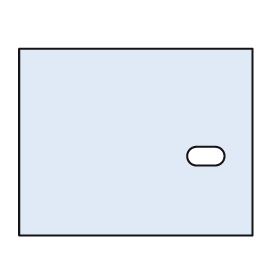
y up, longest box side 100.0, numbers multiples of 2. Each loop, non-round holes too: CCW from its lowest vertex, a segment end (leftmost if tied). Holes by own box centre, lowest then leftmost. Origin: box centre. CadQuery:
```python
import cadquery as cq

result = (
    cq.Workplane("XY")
    .moveTo(-50.0, -40.0)
    .lineTo(50.0, -40.0)
    .lineTo(50.0, 40.0)
    .lineTo(-50.0, 40.0)
    .close()
    .moveTo(26.0, -10.0)
    .lineTo(34.0, -10.0)
    .threePointArc((38.0, -6.0), (34.0, -2.0))
    .lineTo(26.0, -2.0)
    .threePointArc((22.0, -6.0), (26.0, -10.0))
    .close()
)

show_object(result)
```